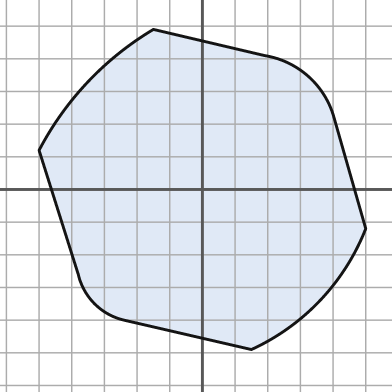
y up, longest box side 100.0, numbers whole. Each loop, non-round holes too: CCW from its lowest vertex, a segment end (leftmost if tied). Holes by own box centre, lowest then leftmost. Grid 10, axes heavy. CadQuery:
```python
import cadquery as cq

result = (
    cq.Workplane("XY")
    .moveTo(15.0, -49.0)
    .threePointArc((36.0, -34.0), (50.0, -12.0))
    .lineTo(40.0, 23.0)
    .threePointArc((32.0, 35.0), (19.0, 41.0))
    .lineTo(-15.0, 49.0)
    .threePointArc((-35.0, 33.0), (-50.0, 12.0))
    .lineTo(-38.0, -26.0)
    .threePointArc((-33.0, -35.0), (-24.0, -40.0))
    .close()
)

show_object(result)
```